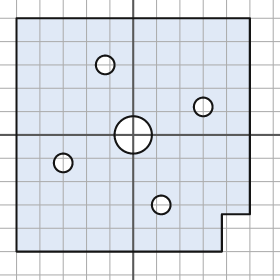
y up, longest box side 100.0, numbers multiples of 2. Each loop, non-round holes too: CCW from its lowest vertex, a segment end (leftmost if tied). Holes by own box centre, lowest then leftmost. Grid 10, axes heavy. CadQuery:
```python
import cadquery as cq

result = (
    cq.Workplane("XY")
    .moveTo(-50.0, -50.0)
    .lineTo(38.0, -50.0)
    .lineTo(38.0, -34.0)
    .lineTo(50.0, -34.0)
    .lineTo(50.0, 50.0)
    .lineTo(-50.0, 50.0)
    .close()
    .moveTo(12.0, -30.0)
    .circle(4.0)
    .moveTo(-30.0, -12.0)
    .circle(4.0)
    .moveTo(0.0, 0.0)
    .circle(8.0)
    .moveTo(30.0, 12.0)
    .circle(4.0)
    .moveTo(-12.0, 30.0)
    .circle(4.0)
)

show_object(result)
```